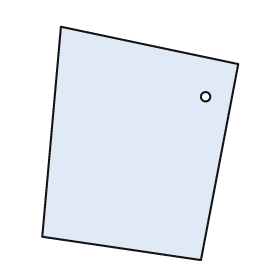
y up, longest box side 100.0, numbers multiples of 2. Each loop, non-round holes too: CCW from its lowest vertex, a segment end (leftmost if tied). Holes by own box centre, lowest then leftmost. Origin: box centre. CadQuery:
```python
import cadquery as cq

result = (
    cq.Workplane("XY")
    .moveTo(26.0, -50.0)
    .lineTo(42.0, 34.0)
    .lineTo(-34.0, 50.0)
    .lineTo(-42.0, -40.0)
    .close()
    .moveTo(28.0, 20.0)
    .circle(2.0)
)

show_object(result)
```